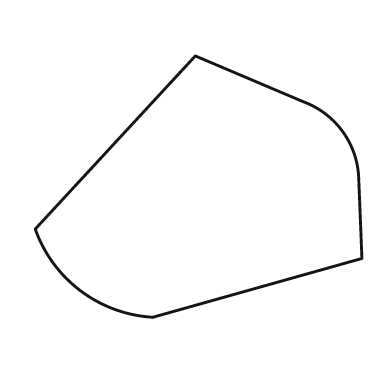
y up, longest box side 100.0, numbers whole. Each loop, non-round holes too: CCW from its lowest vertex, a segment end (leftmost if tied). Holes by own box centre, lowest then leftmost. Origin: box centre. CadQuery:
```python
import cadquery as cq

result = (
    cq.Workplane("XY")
    .moveTo(-14.0, -40.0)
    .lineTo(50.0, -22.0)
    .lineTo(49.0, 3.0)
    .threePointArc((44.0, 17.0), (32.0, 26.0))
    .lineTo(-1.0, 40.0)
    .lineTo(-50.0, -13.0)
    .threePointArc((-36.0, -32.0), (-14.0, -40.0))
    .close()
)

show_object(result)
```